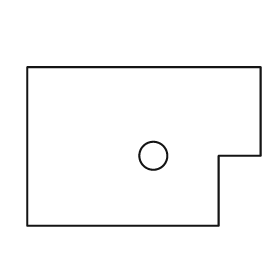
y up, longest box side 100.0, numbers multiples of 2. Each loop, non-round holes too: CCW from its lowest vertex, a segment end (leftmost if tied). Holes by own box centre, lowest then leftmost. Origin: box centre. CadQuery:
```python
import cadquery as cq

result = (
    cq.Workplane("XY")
    .moveTo(-50.0, -34.0)
    .lineTo(32.0, -34.0)
    .lineTo(32.0, -4.0)
    .lineTo(50.0, -4.0)
    .lineTo(50.0, 34.0)
    .lineTo(-50.0, 34.0)
    .close()
    .moveTo(4.0, -4.0)
    .circle(6.0)
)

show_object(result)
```